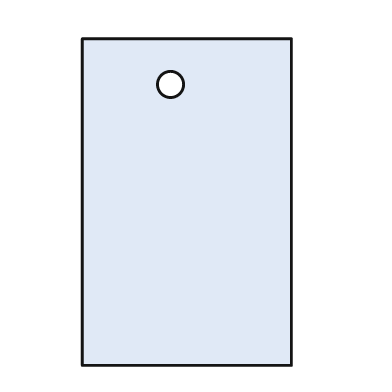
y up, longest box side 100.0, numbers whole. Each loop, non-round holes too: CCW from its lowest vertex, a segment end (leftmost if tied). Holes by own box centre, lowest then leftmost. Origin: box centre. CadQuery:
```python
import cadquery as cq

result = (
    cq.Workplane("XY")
    .moveTo(-32.0, -50.0)
    .lineTo(32.0, -50.0)
    .lineTo(32.0, 50.0)
    .lineTo(-32.0, 50.0)
    .close()
    .moveTo(-5.0, 36.0)
    .circle(4.0)
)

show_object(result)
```